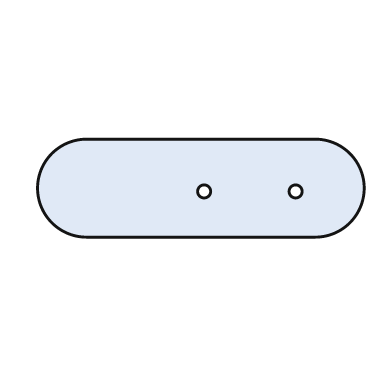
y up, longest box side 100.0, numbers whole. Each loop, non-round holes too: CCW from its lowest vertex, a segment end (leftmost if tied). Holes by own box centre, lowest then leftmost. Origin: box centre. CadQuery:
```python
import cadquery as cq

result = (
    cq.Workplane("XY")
    .moveTo(-35.0, -15.0)
    .lineTo(35.0, -15.0)
    .threePointArc((50.0, 0.0), (35.0, 15.0))
    .lineTo(-35.0, 15.0)
    .threePointArc((-50.0, 0.0), (-35.0, -15.0))
    .close()
    .moveTo(1.0, -1.0)
    .circle(2.0)
    .moveTo(29.0, -1.0)
    .circle(2.0)
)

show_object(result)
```